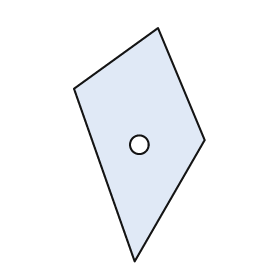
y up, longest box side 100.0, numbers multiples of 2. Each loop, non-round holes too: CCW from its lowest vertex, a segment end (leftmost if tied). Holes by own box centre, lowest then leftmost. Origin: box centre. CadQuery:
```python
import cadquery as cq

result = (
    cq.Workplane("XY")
    .moveTo(-2.0, -50.0)
    .lineTo(28.0, 2.0)
    .lineTo(8.0, 50.0)
    .lineTo(-28.0, 24.0)
    .close()
    .moveTo(0.0, 0.0)
    .circle(4.0)
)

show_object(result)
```